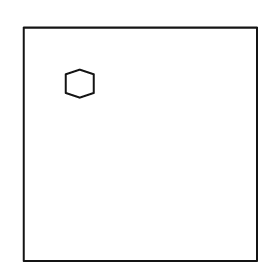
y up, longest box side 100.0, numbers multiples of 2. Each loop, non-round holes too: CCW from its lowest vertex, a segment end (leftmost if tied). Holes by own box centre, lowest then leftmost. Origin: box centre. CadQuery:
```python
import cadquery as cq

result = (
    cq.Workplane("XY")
    .moveTo(-50.0, -50.0)
    .lineTo(50.0, -50.0)
    .lineTo(50.0, 50.0)
    .lineTo(-50.0, 50.0)
    .close()
    .moveTo(-26.0, 20.0)
    .lineTo(-20.0, 22.0)
    .lineTo(-20.0, 30.0)
    .lineTo(-26.0, 32.0)
    .lineTo(-32.0, 30.0)
    .lineTo(-32.0, 22.0)
    .close()
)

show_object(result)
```